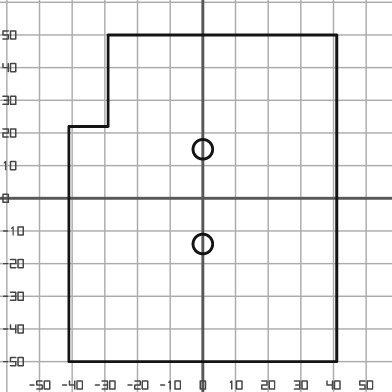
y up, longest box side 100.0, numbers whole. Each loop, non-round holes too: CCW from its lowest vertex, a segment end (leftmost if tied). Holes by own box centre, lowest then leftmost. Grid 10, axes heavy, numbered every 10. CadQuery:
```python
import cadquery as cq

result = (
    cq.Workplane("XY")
    .moveTo(-41.0, -50.0)
    .lineTo(41.0, -50.0)
    .lineTo(41.0, 50.0)
    .lineTo(-29.0, 50.0)
    .lineTo(-29.0, 22.0)
    .lineTo(-41.0, 22.0)
    .close()
    .moveTo(0.0, -14.0)
    .circle(3.0)
    .moveTo(0.0, 15.0)
    .circle(3.0)
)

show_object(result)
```